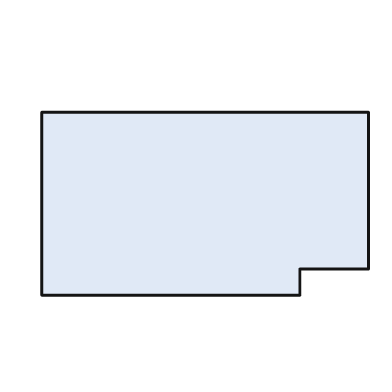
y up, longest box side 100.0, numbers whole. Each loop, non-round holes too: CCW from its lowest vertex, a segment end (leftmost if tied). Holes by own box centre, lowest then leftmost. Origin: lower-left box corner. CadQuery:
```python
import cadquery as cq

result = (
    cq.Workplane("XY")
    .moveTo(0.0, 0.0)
    .lineTo(79.0, 0.0)
    .lineTo(79.0, 8.0)
    .lineTo(100.0, 8.0)
    .lineTo(100.0, 56.0)
    .lineTo(0.0, 56.0)
    .close()
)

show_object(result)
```